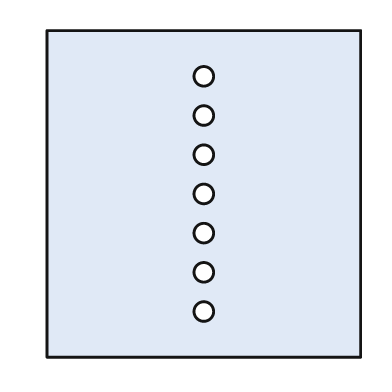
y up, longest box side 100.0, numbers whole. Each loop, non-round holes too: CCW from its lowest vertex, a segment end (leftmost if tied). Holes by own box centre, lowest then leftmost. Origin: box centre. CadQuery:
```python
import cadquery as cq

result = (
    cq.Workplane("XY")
    .moveTo(-48.0, -50.0)
    .lineTo(48.0, -50.0)
    .lineTo(48.0, 50.0)
    .lineTo(-48.0, 50.0)
    .close()
    .moveTo(0.0, -36.0)
    .circle(3.0)
    .moveTo(0.0, -24.0)
    .circle(3.0)
    .moveTo(0.0, -12.0)
    .circle(3.0)
    .moveTo(0.0, 0.0)
    .circle(3.0)
    .moveTo(0.0, 12.0)
    .circle(3.0)
    .moveTo(0.0, 24.0)
    .circle(3.0)
    .moveTo(0.0, 36.0)
    .circle(3.0)
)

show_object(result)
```